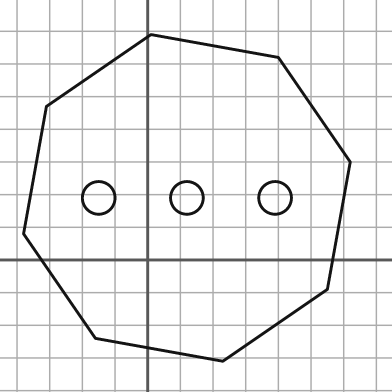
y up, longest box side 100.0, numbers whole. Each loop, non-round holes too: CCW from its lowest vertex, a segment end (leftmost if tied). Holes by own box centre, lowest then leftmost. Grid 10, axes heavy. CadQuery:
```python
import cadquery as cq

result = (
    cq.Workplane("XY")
    .moveTo(23.0, -31.0)
    .lineTo(55.0, -9.0)
    .lineTo(62.0, 30.0)
    .lineTo(40.0, 62.0)
    .lineTo(1.0, 69.0)
    .lineTo(-31.0, 47.0)
    .lineTo(-38.0, 8.0)
    .lineTo(-16.0, -24.0)
    .close()
    .moveTo(-15.0, 19.0)
    .circle(5.0)
    .moveTo(12.0, 19.0)
    .circle(5.0)
    .moveTo(39.0, 19.0)
    .circle(5.0)
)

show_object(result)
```